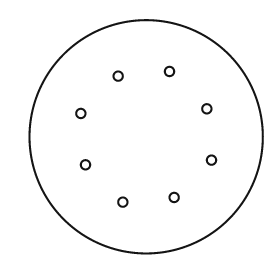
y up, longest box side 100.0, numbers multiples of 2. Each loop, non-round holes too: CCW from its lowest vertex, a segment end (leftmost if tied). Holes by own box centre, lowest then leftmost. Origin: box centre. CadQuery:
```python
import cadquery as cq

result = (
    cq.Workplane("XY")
    .moveTo(0.0, 0.0)
    .circle(50.0)
    .moveTo(-10.0, -28.0)
    .circle(2.0)
    .moveTo(12.0, -26.0)
    .circle(2.0)
    .moveTo(-26.0, -12.0)
    .circle(2.0)
    .moveTo(28.0, -10.0)
    .circle(2.0)
    .moveTo(-28.0, 10.0)
    .circle(2.0)
    .moveTo(26.0, 12.0)
    .circle(2.0)
    .moveTo(-12.0, 26.0)
    .circle(2.0)
    .moveTo(10.0, 28.0)
    .circle(2.0)
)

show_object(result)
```